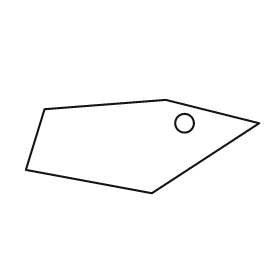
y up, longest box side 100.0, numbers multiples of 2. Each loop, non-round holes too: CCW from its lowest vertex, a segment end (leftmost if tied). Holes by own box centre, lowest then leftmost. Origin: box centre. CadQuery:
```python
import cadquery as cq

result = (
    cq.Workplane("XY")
    .moveTo(4.0, -20.0)
    .lineTo(50.0, 10.0)
    .lineTo(10.0, 20.0)
    .lineTo(-42.0, 16.0)
    .lineTo(-50.0, -10.0)
    .close()
    .moveTo(18.0, 10.0)
    .circle(4.0)
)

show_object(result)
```